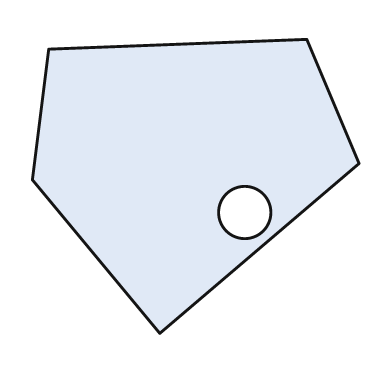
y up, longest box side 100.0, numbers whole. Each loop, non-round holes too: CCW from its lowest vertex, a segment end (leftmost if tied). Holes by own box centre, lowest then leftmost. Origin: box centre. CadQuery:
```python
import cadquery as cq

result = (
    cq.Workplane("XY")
    .moveTo(-11.0, -45.0)
    .lineTo(50.0, 7.0)
    .lineTo(34.0, 45.0)
    .lineTo(-45.0, 42.0)
    .lineTo(-50.0, 2.0)
    .close()
    .moveTo(15.0, -8.0)
    .circle(8.0)
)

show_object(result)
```